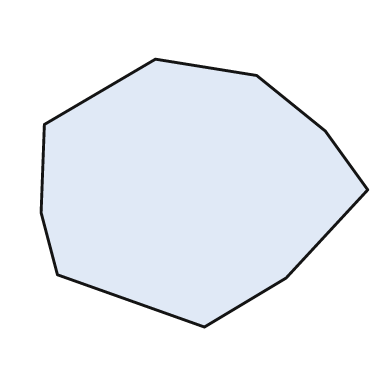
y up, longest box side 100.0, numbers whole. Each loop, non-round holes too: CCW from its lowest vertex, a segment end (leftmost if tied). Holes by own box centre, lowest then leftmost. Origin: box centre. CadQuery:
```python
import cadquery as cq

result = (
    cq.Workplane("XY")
    .moveTo(0.0, -41.0)
    .lineTo(25.0, -26.0)
    .lineTo(50.0, 1.0)
    .lineTo(37.0, 19.0)
    .lineTo(16.0, 36.0)
    .lineTo(-15.0, 41.0)
    .lineTo(-49.0, 21.0)
    .lineTo(-50.0, -6.0)
    .lineTo(-45.0, -25.0)
    .close()
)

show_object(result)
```